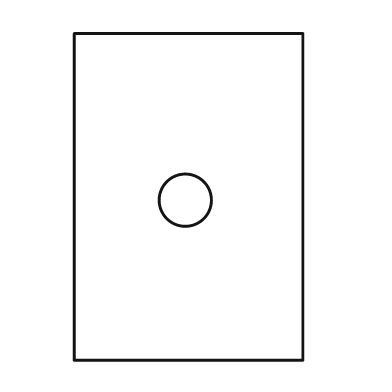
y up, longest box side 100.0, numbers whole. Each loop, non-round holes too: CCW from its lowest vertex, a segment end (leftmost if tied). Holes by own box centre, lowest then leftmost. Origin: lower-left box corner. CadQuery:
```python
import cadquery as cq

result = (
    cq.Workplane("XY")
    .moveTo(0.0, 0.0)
    .lineTo(70.0, 0.0)
    .lineTo(70.0, 100.0)
    .lineTo(0.0, 100.0)
    .close()
    .moveTo(34.0, 49.0)
    .circle(8.0)
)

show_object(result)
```